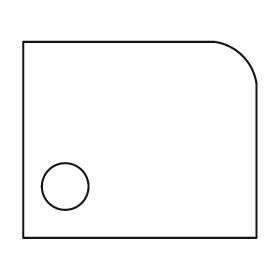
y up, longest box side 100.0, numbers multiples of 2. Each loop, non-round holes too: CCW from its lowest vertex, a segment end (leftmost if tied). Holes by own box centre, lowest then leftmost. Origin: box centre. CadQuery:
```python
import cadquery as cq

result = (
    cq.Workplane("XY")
    .moveTo(-50.0, -42.0)
    .lineTo(50.0, -42.0)
    .lineTo(50.0, 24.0)
    .threePointArc((44.0, 36.0), (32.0, 42.0))
    .lineTo(-50.0, 42.0)
    .close()
    .moveTo(-32.0, -20.0)
    .circle(10.0)
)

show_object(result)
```